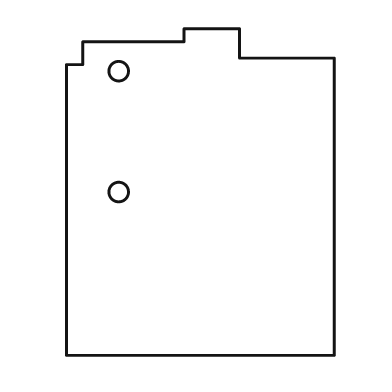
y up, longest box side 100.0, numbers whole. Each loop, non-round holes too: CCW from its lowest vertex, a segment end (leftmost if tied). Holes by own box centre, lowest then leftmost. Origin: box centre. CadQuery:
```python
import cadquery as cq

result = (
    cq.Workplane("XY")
    .moveTo(-41.0, -50.0)
    .lineTo(41.0, -50.0)
    .lineTo(41.0, 41.0)
    .lineTo(12.0, 41.0)
    .lineTo(12.0, 50.0)
    .lineTo(-5.0, 50.0)
    .lineTo(-5.0, 46.0)
    .lineTo(-36.0, 46.0)
    .lineTo(-36.0, 39.0)
    .lineTo(-41.0, 39.0)
    .close()
    .moveTo(-25.0, 0.0)
    .circle(3.0)
    .moveTo(-25.0, 37.0)
    .circle(3.0)
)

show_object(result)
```